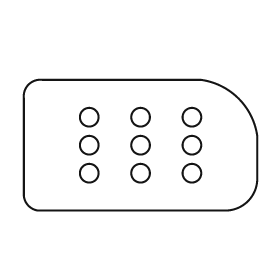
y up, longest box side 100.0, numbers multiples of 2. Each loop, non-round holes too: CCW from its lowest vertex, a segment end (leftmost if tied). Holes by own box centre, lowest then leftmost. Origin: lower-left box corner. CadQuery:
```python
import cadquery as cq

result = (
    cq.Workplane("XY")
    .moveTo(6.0, 0.0)
    .lineTo(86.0, 0.0)
    .threePointArc((96.0, 4.0), (100.0, 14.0))
    .lineTo(100.0, 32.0)
    .threePointArc((92.0, 48.0), (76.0, 56.0))
    .lineTo(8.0, 56.0)
    .threePointArc((2.0, 54.0), (0.0, 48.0))
    .lineTo(0.0, 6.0)
    .threePointArc((2.0, 2.0), (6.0, 0.0))
    .close()
    .moveTo(28.0, 16.0)
    .circle(4.0)
    .moveTo(50.0, 16.0)
    .circle(4.0)
    .moveTo(72.0, 16.0)
    .circle(4.0)
    .moveTo(28.0, 28.0)
    .circle(4.0)
    .moveTo(50.0, 28.0)
    .circle(4.0)
    .moveTo(72.0, 28.0)
    .circle(4.0)
    .moveTo(28.0, 40.0)
    .circle(4.0)
    .moveTo(50.0, 40.0)
    .circle(4.0)
    .moveTo(72.0, 40.0)
    .circle(4.0)
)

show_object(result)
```